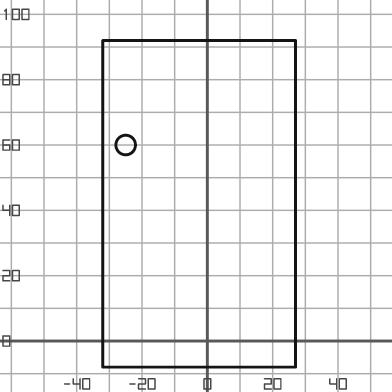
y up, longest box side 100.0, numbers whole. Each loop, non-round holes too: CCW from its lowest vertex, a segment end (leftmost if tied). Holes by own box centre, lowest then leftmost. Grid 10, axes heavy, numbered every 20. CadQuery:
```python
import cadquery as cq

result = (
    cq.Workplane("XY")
    .moveTo(-32.0, -8.0)
    .lineTo(27.0, -8.0)
    .lineTo(27.0, 92.0)
    .lineTo(-32.0, 92.0)
    .close()
    .moveTo(-25.0, 60.0)
    .circle(3.0)
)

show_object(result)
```